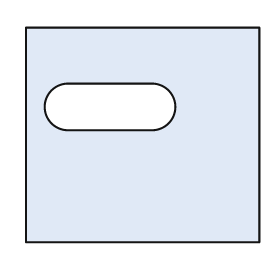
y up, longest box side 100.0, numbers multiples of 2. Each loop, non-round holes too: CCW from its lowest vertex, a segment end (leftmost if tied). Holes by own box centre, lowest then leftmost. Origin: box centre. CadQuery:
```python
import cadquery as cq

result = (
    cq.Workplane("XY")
    .moveTo(-50.0, -46.0)
    .lineTo(50.0, -46.0)
    .lineTo(50.0, 46.0)
    .lineTo(-50.0, 46.0)
    .close()
    .moveTo(-32.0, 2.0)
    .lineTo(4.0, 2.0)
    .threePointArc((14.0, 12.0), (4.0, 22.0))
    .lineTo(-32.0, 22.0)
    .threePointArc((-42.0, 12.0), (-32.0, 2.0))
    .close()
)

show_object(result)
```